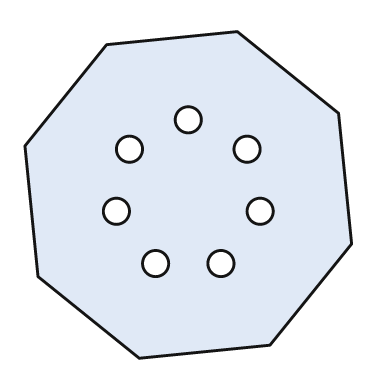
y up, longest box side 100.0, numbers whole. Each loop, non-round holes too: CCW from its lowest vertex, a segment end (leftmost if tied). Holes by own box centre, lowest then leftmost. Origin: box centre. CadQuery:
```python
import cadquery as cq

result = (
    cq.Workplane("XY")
    .moveTo(-15.0, -50.0)
    .lineTo(25.0, -46.0)
    .lineTo(50.0, -15.0)
    .lineTo(46.0, 25.0)
    .lineTo(15.0, 50.0)
    .lineTo(-25.0, 46.0)
    .lineTo(-50.0, 15.0)
    .lineTo(-46.0, -25.0)
    .close()
    .moveTo(-10.0, -21.0)
    .circle(4.0)
    .moveTo(10.0, -21.0)
    .circle(4.0)
    .moveTo(-22.0, -5.0)
    .circle(4.0)
    .moveTo(22.0, -5.0)
    .circle(4.0)
    .moveTo(-18.0, 14.0)
    .circle(4.0)
    .moveTo(18.0, 14.0)
    .circle(4.0)
    .moveTo(0.0, 23.0)
    .circle(4.0)
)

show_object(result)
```